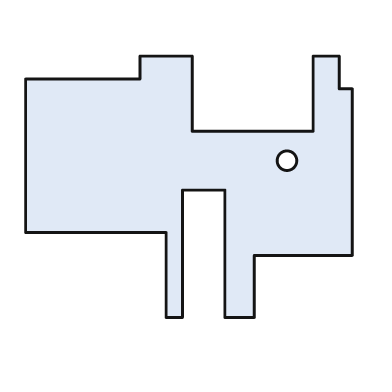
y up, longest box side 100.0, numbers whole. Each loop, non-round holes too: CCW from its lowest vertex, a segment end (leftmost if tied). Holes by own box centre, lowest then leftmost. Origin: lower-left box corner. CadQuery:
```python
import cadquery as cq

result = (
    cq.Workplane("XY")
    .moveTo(43.0, 0.0)
    .lineTo(48.0, 0.0)
    .lineTo(48.0, 39.0)
    .lineTo(61.0, 39.0)
    .lineTo(61.0, 0.0)
    .lineTo(70.0, 0.0)
    .lineTo(70.0, 19.0)
    .lineTo(100.0, 19.0)
    .lineTo(100.0, 70.0)
    .lineTo(96.0, 70.0)
    .lineTo(96.0, 80.0)
    .lineTo(88.0, 80.0)
    .lineTo(88.0, 57.0)
    .lineTo(51.0, 57.0)
    .lineTo(51.0, 80.0)
    .lineTo(35.0, 80.0)
    .lineTo(35.0, 73.0)
    .lineTo(0.0, 73.0)
    .lineTo(0.0, 26.0)
    .lineTo(43.0, 26.0)
    .close()
    .moveTo(80.0, 48.0)
    .circle(3.0)
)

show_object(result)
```